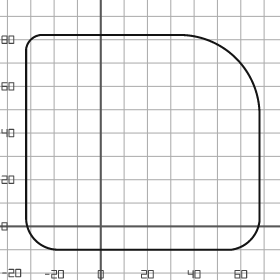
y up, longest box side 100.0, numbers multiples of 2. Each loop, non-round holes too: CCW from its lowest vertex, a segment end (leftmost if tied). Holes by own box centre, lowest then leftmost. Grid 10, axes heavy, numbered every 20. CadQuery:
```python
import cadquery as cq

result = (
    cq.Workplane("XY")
    .moveTo(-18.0, -10.0)
    .lineTo(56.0, -10.0)
    .threePointArc((64.0, -6.0), (68.0, 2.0))
    .lineTo(68.0, 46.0)
    .threePointArc((58.0, 72.0), (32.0, 82.0))
    .lineTo(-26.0, 82.0)
    .threePointArc((-30.0, 80.0), (-32.0, 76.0))
    .lineTo(-32.0, 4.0)
    .threePointArc((-28.0, -6.0), (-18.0, -10.0))
    .close()
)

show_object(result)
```